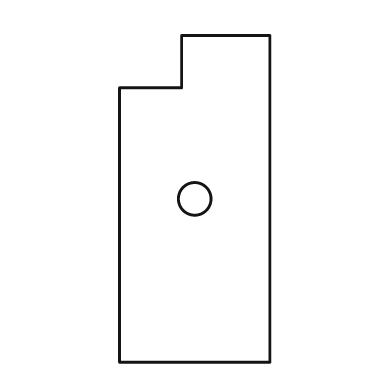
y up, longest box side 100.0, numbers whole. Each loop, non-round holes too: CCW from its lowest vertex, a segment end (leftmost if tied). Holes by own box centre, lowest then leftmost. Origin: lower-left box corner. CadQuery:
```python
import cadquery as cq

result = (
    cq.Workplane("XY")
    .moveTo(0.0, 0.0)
    .lineTo(46.0, 0.0)
    .lineTo(46.0, 100.0)
    .lineTo(19.0, 100.0)
    .lineTo(19.0, 84.0)
    .lineTo(0.0, 84.0)
    .close()
    .moveTo(23.0, 50.0)
    .circle(5.0)
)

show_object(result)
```